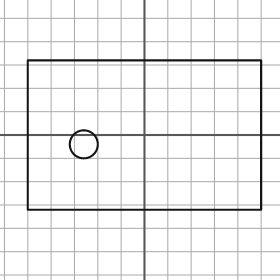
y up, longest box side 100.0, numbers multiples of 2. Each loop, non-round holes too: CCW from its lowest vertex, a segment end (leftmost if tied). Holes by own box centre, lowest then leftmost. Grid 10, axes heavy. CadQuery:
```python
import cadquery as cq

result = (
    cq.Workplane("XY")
    .moveTo(-50.0, -32.0)
    .lineTo(50.0, -32.0)
    .lineTo(50.0, 32.0)
    .lineTo(-50.0, 32.0)
    .close()
    .moveTo(-26.0, -4.0)
    .circle(6.0)
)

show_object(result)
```